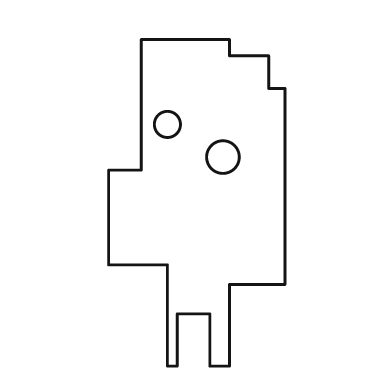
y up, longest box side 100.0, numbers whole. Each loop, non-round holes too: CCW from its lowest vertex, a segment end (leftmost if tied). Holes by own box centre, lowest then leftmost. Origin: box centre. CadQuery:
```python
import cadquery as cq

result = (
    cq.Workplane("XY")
    .moveTo(-9.0, -50.0)
    .lineTo(-6.0, -50.0)
    .lineTo(-6.0, -34.0)
    .lineTo(4.0, -34.0)
    .lineTo(4.0, -50.0)
    .lineTo(10.0, -50.0)
    .lineTo(10.0, -25.0)
    .lineTo(27.0, -25.0)
    .lineTo(27.0, 35.0)
    .lineTo(22.0, 35.0)
    .lineTo(22.0, 45.0)
    .lineTo(10.0, 45.0)
    .lineTo(10.0, 50.0)
    .lineTo(-17.0, 50.0)
    .lineTo(-17.0, 10.0)
    .lineTo(-27.0, 10.0)
    .lineTo(-27.0, -19.0)
    .lineTo(-9.0, -19.0)
    .close()
    .moveTo(8.0, 14.0)
    .circle(5.0)
    .moveTo(-9.0, 24.0)
    .circle(4.0)
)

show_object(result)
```